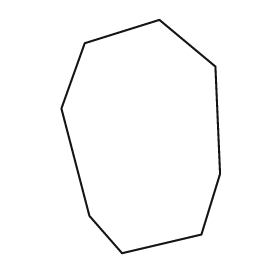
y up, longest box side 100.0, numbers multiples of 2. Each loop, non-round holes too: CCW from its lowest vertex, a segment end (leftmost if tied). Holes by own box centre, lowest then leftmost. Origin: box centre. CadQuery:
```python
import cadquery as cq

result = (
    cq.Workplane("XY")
    .moveTo(-8.0, -50.0)
    .lineTo(26.0, -42.0)
    .lineTo(34.0, -16.0)
    .lineTo(32.0, 30.0)
    .lineTo(8.0, 50.0)
    .lineTo(-24.0, 40.0)
    .lineTo(-34.0, 12.0)
    .lineTo(-22.0, -34.0)
    .close()
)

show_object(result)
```